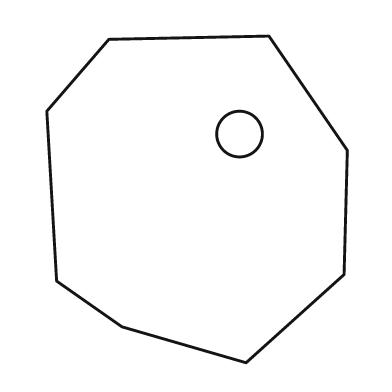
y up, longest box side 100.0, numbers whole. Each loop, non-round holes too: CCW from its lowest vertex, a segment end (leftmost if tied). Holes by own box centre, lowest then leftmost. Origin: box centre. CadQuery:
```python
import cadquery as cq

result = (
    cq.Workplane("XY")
    .moveTo(15.0, -50.0)
    .lineTo(45.0, -23.0)
    .lineTo(46.0, 15.0)
    .lineTo(22.0, 50.0)
    .lineTo(-27.0, 49.0)
    .lineTo(-46.0, 27.0)
    .lineTo(-43.0, -25.0)
    .lineTo(-23.0, -39.0)
    .close()
    .moveTo(13.0, 20.0)
    .circle(7.0)
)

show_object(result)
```